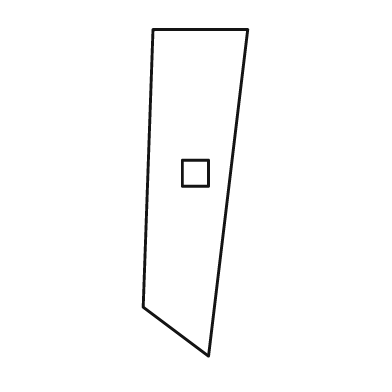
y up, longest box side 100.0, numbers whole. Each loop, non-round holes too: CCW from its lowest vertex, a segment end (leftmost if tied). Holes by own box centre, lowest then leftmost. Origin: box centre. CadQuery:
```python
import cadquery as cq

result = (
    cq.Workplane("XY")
    .moveTo(4.0, -50.0)
    .lineTo(16.0, 50.0)
    .lineTo(-13.0, 50.0)
    .lineTo(-16.0, -35.0)
    .close()
    .moveTo(-4.0, 2.0)
    .lineTo(4.0, 2.0)
    .lineTo(4.0, 10.0)
    .lineTo(-4.0, 10.0)
    .close()
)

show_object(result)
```